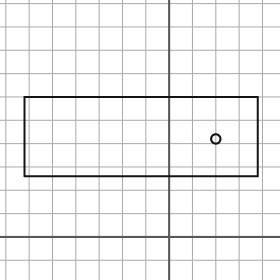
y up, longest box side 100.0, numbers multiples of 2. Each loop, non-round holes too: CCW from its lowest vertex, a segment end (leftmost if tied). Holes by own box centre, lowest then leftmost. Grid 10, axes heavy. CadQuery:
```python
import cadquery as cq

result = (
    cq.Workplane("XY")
    .moveTo(-62.0, 26.0)
    .lineTo(38.0, 26.0)
    .lineTo(38.0, 60.0)
    .lineTo(-62.0, 60.0)
    .close()
    .moveTo(20.0, 42.0)
    .circle(2.0)
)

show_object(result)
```